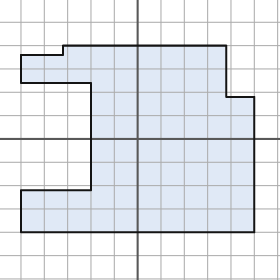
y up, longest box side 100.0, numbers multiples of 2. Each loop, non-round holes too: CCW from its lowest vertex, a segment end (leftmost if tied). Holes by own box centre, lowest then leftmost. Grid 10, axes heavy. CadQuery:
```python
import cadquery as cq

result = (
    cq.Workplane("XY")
    .moveTo(-50.0, -40.0)
    .lineTo(50.0, -40.0)
    .lineTo(50.0, 18.0)
    .lineTo(38.0, 18.0)
    .lineTo(38.0, 40.0)
    .lineTo(-32.0, 40.0)
    .lineTo(-32.0, 36.0)
    .lineTo(-50.0, 36.0)
    .lineTo(-50.0, 24.0)
    .lineTo(-20.0, 24.0)
    .lineTo(-20.0, -22.0)
    .lineTo(-50.0, -22.0)
    .close()
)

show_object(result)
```